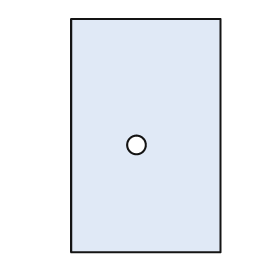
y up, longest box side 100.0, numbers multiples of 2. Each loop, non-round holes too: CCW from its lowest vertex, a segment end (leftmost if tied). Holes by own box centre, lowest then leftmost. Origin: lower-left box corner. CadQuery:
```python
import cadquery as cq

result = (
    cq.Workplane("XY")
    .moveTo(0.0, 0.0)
    .lineTo(64.0, 0.0)
    .lineTo(64.0, 100.0)
    .lineTo(0.0, 100.0)
    .close()
    .moveTo(28.0, 46.0)
    .circle(4.0)
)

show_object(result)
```